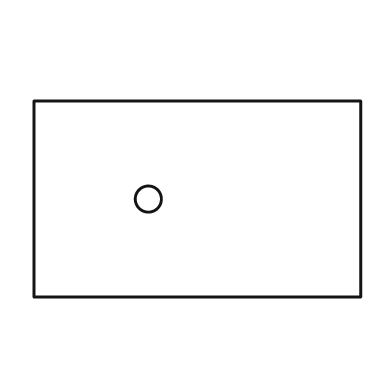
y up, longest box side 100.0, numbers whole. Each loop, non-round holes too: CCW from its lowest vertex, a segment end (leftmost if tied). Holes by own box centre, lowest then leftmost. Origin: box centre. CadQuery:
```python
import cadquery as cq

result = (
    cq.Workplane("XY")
    .moveTo(-50.0, -30.0)
    .lineTo(50.0, -30.0)
    .lineTo(50.0, 30.0)
    .lineTo(-50.0, 30.0)
    .close()
    .moveTo(-15.0, 0.0)
    .circle(4.0)
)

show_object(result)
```